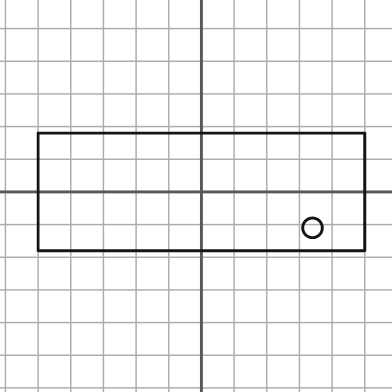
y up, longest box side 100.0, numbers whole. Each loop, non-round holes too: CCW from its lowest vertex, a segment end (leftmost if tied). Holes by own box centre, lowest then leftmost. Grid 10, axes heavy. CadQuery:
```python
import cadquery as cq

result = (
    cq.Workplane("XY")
    .moveTo(-50.0, -18.0)
    .lineTo(50.0, -18.0)
    .lineTo(50.0, 18.0)
    .lineTo(-50.0, 18.0)
    .close()
    .moveTo(34.0, -11.0)
    .circle(3.0)
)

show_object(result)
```